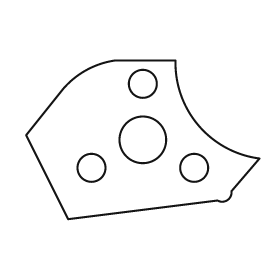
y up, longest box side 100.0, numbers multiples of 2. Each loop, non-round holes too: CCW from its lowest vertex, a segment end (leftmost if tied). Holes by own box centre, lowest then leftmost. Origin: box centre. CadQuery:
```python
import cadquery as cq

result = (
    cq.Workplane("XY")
    .moveTo(-32.0, -34.0)
    .lineTo(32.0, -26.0)
    .threePointArc((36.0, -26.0), (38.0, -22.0))
    .lineTo(50.0, -8.0)
    .threePointArc((24.0, 6.0), (14.0, 34.0))
    .lineTo(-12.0, 34.0)
    .threePointArc((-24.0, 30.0), (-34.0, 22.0))
    .lineTo(-50.0, 2.0)
    .close()
    .moveTo(-22.0, -12.0)
    .circle(6.0)
    .moveTo(22.0, -12.0)
    .circle(6.0)
    .moveTo(0.0, 0.0)
    .circle(10.0)
    .moveTo(0.0, 24.0)
    .circle(6.0)
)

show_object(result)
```